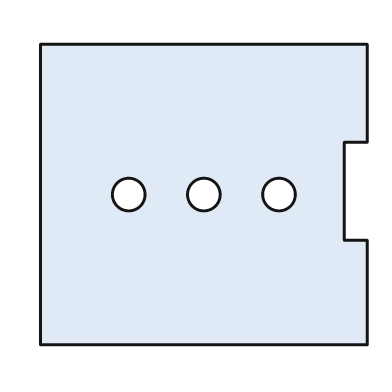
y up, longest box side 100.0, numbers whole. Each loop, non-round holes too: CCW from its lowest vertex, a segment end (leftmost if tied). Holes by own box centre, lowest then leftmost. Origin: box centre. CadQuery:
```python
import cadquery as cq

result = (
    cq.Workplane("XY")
    .moveTo(-50.0, -46.0)
    .lineTo(50.0, -46.0)
    .lineTo(50.0, -14.0)
    .lineTo(43.0, -14.0)
    .lineTo(43.0, 16.0)
    .lineTo(50.0, 16.0)
    .lineTo(50.0, 46.0)
    .lineTo(-50.0, 46.0)
    .close()
    .moveTo(-23.0, 0.0)
    .circle(5.0)
    .moveTo(0.0, 0.0)
    .circle(5.0)
    .moveTo(23.0, 0.0)
    .circle(5.0)
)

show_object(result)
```